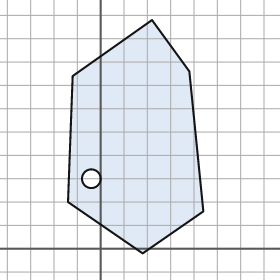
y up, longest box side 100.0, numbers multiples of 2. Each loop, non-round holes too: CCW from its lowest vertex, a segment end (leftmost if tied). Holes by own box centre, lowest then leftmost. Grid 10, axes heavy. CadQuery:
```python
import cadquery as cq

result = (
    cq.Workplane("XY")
    .moveTo(18.0, -2.0)
    .lineTo(44.0, 16.0)
    .lineTo(38.0, 76.0)
    .lineTo(22.0, 98.0)
    .lineTo(-12.0, 74.0)
    .lineTo(-14.0, 20.0)
    .close()
    .moveTo(-4.0, 30.0)
    .circle(4.0)
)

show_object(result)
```